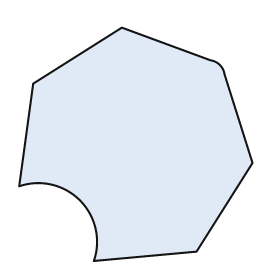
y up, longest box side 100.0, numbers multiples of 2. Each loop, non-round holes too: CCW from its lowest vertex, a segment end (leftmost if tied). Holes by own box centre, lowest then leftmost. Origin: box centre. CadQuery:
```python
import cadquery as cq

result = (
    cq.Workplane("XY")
    .moveTo(-18.0, -50.0)
    .lineTo(26.0, -46.0)
    .lineTo(50.0, -8.0)
    .lineTo(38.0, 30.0)
    .threePointArc((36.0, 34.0), (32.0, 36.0))
    .lineTo(-6.0, 50.0)
    .lineTo(-44.0, 26.0)
    .lineTo(-50.0, -18.0)
    .threePointArc((-24.0, -24.0), (-18.0, -50.0))
    .close()
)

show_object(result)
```